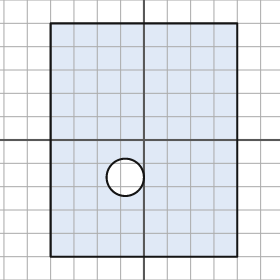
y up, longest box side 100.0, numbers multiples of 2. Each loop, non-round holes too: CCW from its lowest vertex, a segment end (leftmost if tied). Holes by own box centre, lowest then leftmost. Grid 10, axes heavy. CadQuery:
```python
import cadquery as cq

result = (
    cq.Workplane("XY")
    .moveTo(-40.0, -50.0)
    .lineTo(40.0, -50.0)
    .lineTo(40.0, 50.0)
    .lineTo(-40.0, 50.0)
    .close()
    .moveTo(-8.0, -16.0)
    .circle(8.0)
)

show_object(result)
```